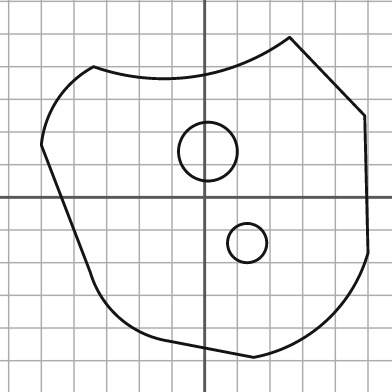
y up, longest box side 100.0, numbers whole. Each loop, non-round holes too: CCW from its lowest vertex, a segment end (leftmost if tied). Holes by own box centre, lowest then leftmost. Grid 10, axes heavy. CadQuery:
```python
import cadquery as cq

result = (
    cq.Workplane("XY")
    .moveTo(15.0, -49.0)
    .threePointArc((37.0, -38.0), (50.0, -17.0))
    .lineTo(49.0, 25.0)
    .lineTo(26.0, 49.0)
    .threePointArc((-3.0, 37.0), (-34.0, 40.0))
    .threePointArc((-45.0, 30.0), (-50.0, 16.0))
    .lineTo(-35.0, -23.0)
    .threePointArc((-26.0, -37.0), (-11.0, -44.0))
    .close()
    .moveTo(13.0, -14.0)
    .circle(6.0)
    .moveTo(1.0, 14.0)
    .circle(9.0)
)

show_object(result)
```